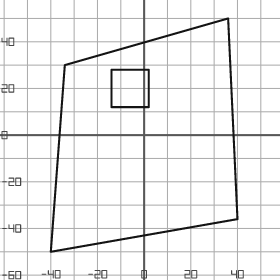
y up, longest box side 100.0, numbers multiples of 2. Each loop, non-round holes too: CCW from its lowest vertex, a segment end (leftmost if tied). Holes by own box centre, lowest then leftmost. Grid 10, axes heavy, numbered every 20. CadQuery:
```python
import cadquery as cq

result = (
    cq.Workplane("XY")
    .moveTo(-40.0, -50.0)
    .lineTo(40.0, -36.0)
    .lineTo(36.0, 50.0)
    .lineTo(-34.0, 30.0)
    .close()
    .moveTo(-14.0, 12.0)
    .lineTo(2.0, 12.0)
    .lineTo(2.0, 28.0)
    .lineTo(-14.0, 28.0)
    .close()
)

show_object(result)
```